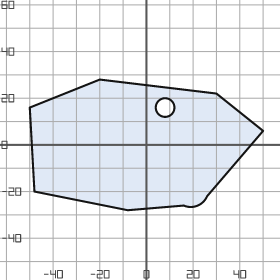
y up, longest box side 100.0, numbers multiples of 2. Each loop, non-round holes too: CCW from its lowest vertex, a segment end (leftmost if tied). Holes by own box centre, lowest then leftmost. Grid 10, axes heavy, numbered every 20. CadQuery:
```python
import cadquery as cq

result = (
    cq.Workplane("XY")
    .moveTo(-8.0, -28.0)
    .lineTo(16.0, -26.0)
    .threePointArc((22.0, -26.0), (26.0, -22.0))
    .lineTo(50.0, 6.0)
    .lineTo(30.0, 22.0)
    .lineTo(-20.0, 28.0)
    .lineTo(-50.0, 16.0)
    .lineTo(-48.0, -20.0)
    .close()
    .moveTo(8.0, 16.0)
    .circle(4.0)
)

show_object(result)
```